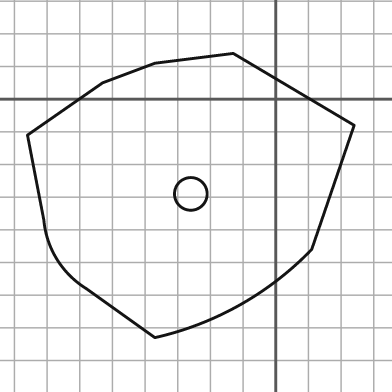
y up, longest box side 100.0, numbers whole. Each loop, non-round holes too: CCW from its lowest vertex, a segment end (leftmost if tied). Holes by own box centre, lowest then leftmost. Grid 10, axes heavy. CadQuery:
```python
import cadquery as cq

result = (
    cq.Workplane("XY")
    .moveTo(-37.0, -73.0)
    .threePointArc((-11.0, -63.0), (11.0, -46.0))
    .lineTo(24.0, -8.0)
    .lineTo(-13.0, 14.0)
    .lineTo(-37.0, 11.0)
    .lineTo(-53.0, 5.0)
    .lineTo(-76.0, -11.0)
    .lineTo(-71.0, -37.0)
    .threePointArc((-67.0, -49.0), (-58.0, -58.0))
    .close()
    .moveTo(-26.0, -29.0)
    .circle(5.0)
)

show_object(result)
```